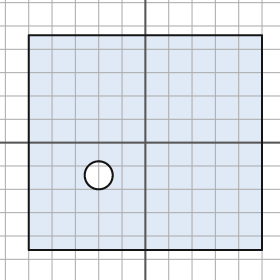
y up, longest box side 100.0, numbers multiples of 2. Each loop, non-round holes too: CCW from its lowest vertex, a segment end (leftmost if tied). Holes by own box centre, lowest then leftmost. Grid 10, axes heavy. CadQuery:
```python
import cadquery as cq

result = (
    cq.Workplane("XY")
    .moveTo(-50.0, -46.0)
    .lineTo(50.0, -46.0)
    .lineTo(50.0, 46.0)
    .lineTo(-50.0, 46.0)
    .close()
    .moveTo(-20.0, -14.0)
    .circle(6.0)
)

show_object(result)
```